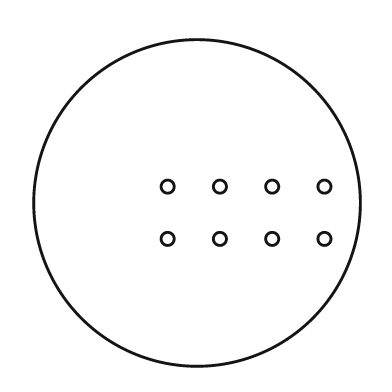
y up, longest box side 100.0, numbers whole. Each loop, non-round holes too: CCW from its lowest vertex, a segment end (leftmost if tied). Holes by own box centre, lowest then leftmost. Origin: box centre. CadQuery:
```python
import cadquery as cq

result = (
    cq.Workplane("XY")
    .moveTo(0.0, 0.0)
    .circle(50.0)
    .moveTo(-9.0, -11.0)
    .circle(2.0)
    .moveTo(7.0, -11.0)
    .circle(2.0)
    .moveTo(23.0, -11.0)
    .circle(2.0)
    .moveTo(39.0, -11.0)
    .circle(2.0)
    .moveTo(-9.0, 5.0)
    .circle(2.0)
    .moveTo(7.0, 5.0)
    .circle(2.0)
    .moveTo(23.0, 5.0)
    .circle(2.0)
    .moveTo(39.0, 5.0)
    .circle(2.0)
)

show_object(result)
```